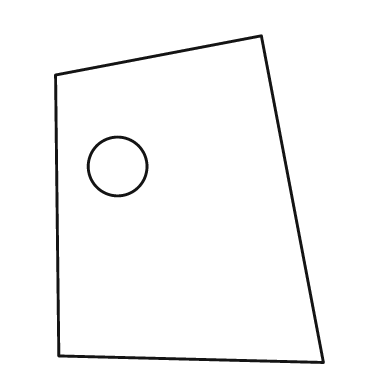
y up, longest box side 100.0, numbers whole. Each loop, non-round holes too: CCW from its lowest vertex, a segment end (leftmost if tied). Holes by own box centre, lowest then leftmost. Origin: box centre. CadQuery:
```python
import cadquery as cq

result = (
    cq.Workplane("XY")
    .moveTo(41.0, -50.0)
    .lineTo(22.0, 50.0)
    .lineTo(-41.0, 38.0)
    .lineTo(-40.0, -48.0)
    .close()
    .moveTo(-22.0, 10.0)
    .circle(9.0)
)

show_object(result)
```